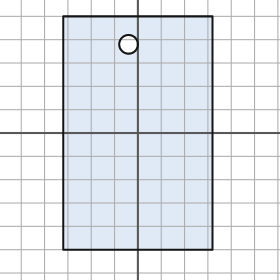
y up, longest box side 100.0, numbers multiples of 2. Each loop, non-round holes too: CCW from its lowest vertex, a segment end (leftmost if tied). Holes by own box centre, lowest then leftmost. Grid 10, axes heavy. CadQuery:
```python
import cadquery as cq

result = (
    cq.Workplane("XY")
    .moveTo(-32.0, -50.0)
    .lineTo(32.0, -50.0)
    .lineTo(32.0, 50.0)
    .lineTo(-32.0, 50.0)
    .close()
    .moveTo(-4.0, 38.0)
    .circle(4.0)
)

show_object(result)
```